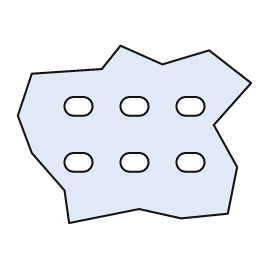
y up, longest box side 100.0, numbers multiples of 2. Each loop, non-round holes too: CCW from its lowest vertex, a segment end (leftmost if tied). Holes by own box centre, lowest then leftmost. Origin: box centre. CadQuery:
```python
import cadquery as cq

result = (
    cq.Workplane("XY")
    .moveTo(-28.0, -38.0)
    .lineTo(2.0, -32.0)
    .lineTo(20.0, -36.0)
    .lineTo(40.0, -34.0)
    .lineTo(44.0, -14.0)
    .lineTo(34.0, 4.0)
    .lineTo(50.0, 22.0)
    .lineTo(32.0, 36.0)
    .lineTo(12.0, 30.0)
    .lineTo(-6.0, 38.0)
    .lineTo(-14.0, 28.0)
    .lineTo(-44.0, 26.0)
    .lineTo(-50.0, 8.0)
    .lineTo(-44.0, -8.0)
    .lineTo(-30.0, -24.0)
    .close()
    .moveTo(-26.0, -16.0)
    .lineTo(-22.0, -16.0)
    .threePointArc((-18.0, -12.0), (-22.0, -8.0))
    .lineTo(-26.0, -8.0)
    .threePointArc((-30.0, -12.0), (-26.0, -16.0))
    .close()
    .moveTo(-2.0, -16.0)
    .lineTo(2.0, -16.0)
    .threePointArc((6.0, -12.0), (2.0, -8.0))
    .lineTo(-2.0, -8.0)
    .threePointArc((-6.0, -12.0), (-2.0, -16.0))
    .close()
    .moveTo(22.0, -16.0)
    .lineTo(26.0, -16.0)
    .threePointArc((30.0, -12.0), (26.0, -8.0))
    .lineTo(22.0, -8.0)
    .threePointArc((18.0, -12.0), (22.0, -16.0))
    .close()
    .moveTo(-26.0, 8.0)
    .lineTo(-22.0, 8.0)
    .threePointArc((-18.0, 12.0), (-22.0, 16.0))
    .lineTo(-26.0, 16.0)
    .threePointArc((-30.0, 12.0), (-26.0, 8.0))
    .close()
    .moveTo(-2.0, 8.0)
    .lineTo(2.0, 8.0)
    .threePointArc((6.0, 12.0), (2.0, 16.0))
    .lineTo(-2.0, 16.0)
    .threePointArc((-6.0, 12.0), (-2.0, 8.0))
    .close()
    .moveTo(22.0, 8.0)
    .lineTo(26.0, 8.0)
    .threePointArc((30.0, 12.0), (26.0, 16.0))
    .lineTo(22.0, 16.0)
    .threePointArc((18.0, 12.0), (22.0, 8.0))
    .close()
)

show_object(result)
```